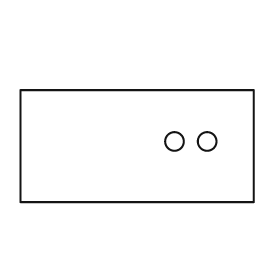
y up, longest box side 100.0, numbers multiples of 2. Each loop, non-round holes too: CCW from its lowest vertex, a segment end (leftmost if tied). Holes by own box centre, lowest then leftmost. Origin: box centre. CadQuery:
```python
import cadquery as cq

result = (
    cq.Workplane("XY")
    .moveTo(-50.0, -24.0)
    .lineTo(50.0, -24.0)
    .lineTo(50.0, 24.0)
    .lineTo(-50.0, 24.0)
    .close()
    .moveTo(16.0, 2.0)
    .circle(4.0)
    .moveTo(30.0, 2.0)
    .circle(4.0)
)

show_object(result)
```